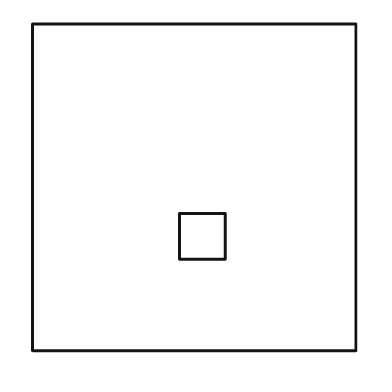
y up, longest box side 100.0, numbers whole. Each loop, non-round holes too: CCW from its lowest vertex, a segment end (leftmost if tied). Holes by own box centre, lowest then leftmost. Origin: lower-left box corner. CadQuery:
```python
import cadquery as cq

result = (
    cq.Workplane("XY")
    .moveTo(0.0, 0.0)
    .lineTo(99.0, 0.0)
    .lineTo(99.0, 100.0)
    .lineTo(0.0, 100.0)
    .close()
    .moveTo(45.0, 28.0)
    .lineTo(59.0, 28.0)
    .lineTo(59.0, 42.0)
    .lineTo(45.0, 42.0)
    .close()
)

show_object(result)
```